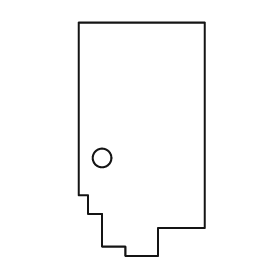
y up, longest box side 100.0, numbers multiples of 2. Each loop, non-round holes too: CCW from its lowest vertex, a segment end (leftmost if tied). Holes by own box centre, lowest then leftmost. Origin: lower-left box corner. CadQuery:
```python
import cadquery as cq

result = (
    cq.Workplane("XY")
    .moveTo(20.0, 0.0)
    .lineTo(34.0, 0.0)
    .lineTo(34.0, 12.0)
    .lineTo(54.0, 12.0)
    .lineTo(54.0, 100.0)
    .lineTo(0.0, 100.0)
    .lineTo(0.0, 26.0)
    .lineTo(4.0, 26.0)
    .lineTo(4.0, 18.0)
    .lineTo(10.0, 18.0)
    .lineTo(10.0, 4.0)
    .lineTo(20.0, 4.0)
    .close()
    .moveTo(10.0, 42.0)
    .circle(4.0)
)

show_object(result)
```